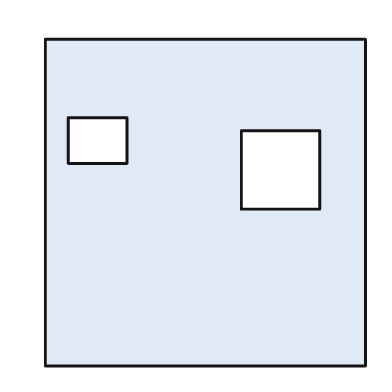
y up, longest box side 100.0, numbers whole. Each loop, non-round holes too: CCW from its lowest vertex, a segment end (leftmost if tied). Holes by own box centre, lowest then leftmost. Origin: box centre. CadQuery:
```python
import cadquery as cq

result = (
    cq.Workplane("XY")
    .moveTo(-49.0, -50.0)
    .lineTo(49.0, -50.0)
    .lineTo(49.0, 50.0)
    .lineTo(-49.0, 50.0)
    .close()
    .moveTo(11.0, -2.0)
    .lineTo(35.0, -2.0)
    .lineTo(35.0, 22.0)
    .lineTo(11.0, 22.0)
    .close()
    .moveTo(-42.0, 12.0)
    .lineTo(-24.0, 12.0)
    .lineTo(-24.0, 26.0)
    .lineTo(-42.0, 26.0)
    .close()
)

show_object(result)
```